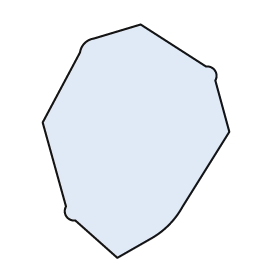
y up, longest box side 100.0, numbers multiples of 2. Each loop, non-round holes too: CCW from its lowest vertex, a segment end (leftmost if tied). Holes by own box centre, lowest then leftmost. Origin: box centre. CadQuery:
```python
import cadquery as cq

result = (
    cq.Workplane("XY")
    .moveTo(-8.0, -50.0)
    .lineTo(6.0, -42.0)
    .threePointArc((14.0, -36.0), (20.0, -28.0))
    .lineTo(40.0, 4.0)
    .lineTo(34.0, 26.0)
    .threePointArc((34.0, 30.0), (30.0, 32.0))
    .lineTo(2.0, 50.0)
    .lineTo(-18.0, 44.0)
    .threePointArc((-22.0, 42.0), (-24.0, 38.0))
    .lineTo(-40.0, 8.0)
    .lineTo(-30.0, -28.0)
    .threePointArc((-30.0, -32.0), (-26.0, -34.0))
    .close()
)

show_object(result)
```